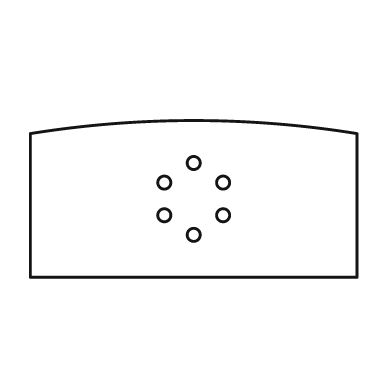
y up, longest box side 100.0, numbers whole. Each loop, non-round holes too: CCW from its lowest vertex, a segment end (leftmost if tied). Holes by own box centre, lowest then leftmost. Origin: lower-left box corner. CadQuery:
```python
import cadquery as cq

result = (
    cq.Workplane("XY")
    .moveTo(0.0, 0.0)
    .lineTo(100.0, 0.0)
    .lineTo(100.0, 44.0)
    .threePointArc((50.0, 48.0), (0.0, 44.0))
    .close()
    .moveTo(50.0, 13.0)
    .circle(2.0)
    .moveTo(41.0, 19.0)
    .circle(2.0)
    .moveTo(59.0, 19.0)
    .circle(2.0)
    .moveTo(41.0, 29.0)
    .circle(2.0)
    .moveTo(59.0, 29.0)
    .circle(2.0)
    .moveTo(50.0, 35.0)
    .circle(2.0)
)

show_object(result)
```